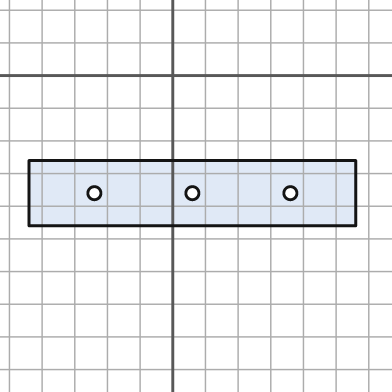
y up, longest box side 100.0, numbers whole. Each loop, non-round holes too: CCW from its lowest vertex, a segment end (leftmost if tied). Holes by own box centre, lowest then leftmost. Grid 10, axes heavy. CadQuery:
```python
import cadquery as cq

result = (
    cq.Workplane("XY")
    .moveTo(-44.0, -46.0)
    .lineTo(56.0, -46.0)
    .lineTo(56.0, -26.0)
    .lineTo(-44.0, -26.0)
    .close()
    .moveTo(-24.0, -36.0)
    .circle(2.0)
    .moveTo(6.0, -36.0)
    .circle(2.0)
    .moveTo(36.0, -36.0)
    .circle(2.0)
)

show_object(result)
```